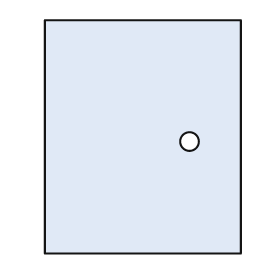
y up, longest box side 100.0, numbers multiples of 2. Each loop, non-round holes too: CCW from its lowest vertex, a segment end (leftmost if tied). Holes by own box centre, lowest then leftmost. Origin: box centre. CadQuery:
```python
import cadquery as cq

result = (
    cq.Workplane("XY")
    .moveTo(-42.0, -50.0)
    .lineTo(42.0, -50.0)
    .lineTo(42.0, 50.0)
    .lineTo(-42.0, 50.0)
    .close()
    .moveTo(20.0, -2.0)
    .circle(4.0)
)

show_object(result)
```